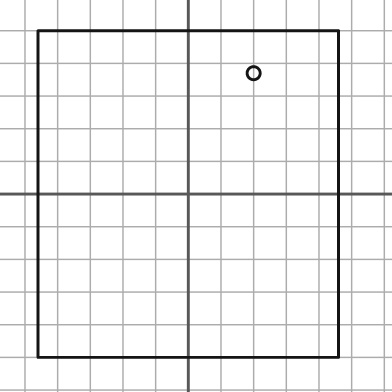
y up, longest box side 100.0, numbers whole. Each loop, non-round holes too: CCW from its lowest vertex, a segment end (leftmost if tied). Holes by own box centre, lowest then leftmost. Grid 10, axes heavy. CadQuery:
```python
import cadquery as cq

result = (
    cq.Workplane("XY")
    .moveTo(-46.0, -50.0)
    .lineTo(46.0, -50.0)
    .lineTo(46.0, 50.0)
    .lineTo(-46.0, 50.0)
    .close()
    .moveTo(20.0, 37.0)
    .circle(2.0)
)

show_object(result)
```